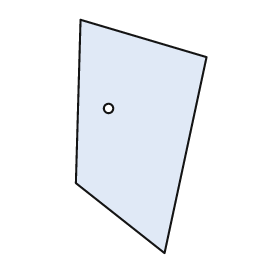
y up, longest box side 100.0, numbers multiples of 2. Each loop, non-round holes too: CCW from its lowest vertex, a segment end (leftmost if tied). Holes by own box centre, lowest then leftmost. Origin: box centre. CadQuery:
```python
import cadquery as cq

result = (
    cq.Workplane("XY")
    .moveTo(10.0, -50.0)
    .lineTo(28.0, 34.0)
    .lineTo(-26.0, 50.0)
    .lineTo(-28.0, -20.0)
    .close()
    .moveTo(-14.0, 12.0)
    .circle(2.0)
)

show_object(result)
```